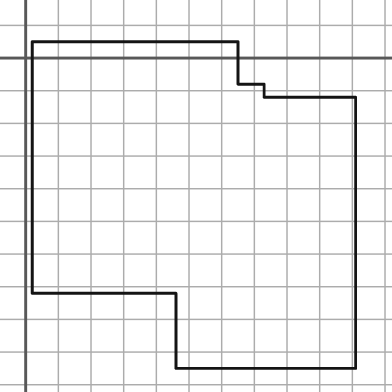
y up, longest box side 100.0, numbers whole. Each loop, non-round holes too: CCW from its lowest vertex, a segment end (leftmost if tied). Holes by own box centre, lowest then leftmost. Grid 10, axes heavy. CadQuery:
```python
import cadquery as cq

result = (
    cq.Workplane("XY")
    .moveTo(46.0, -95.0)
    .lineTo(101.0, -95.0)
    .lineTo(101.0, -12.0)
    .lineTo(73.0, -12.0)
    .lineTo(73.0, -8.0)
    .lineTo(65.0, -8.0)
    .lineTo(65.0, 5.0)
    .lineTo(2.0, 5.0)
    .lineTo(2.0, -72.0)
    .lineTo(46.0, -72.0)
    .close()
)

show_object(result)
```